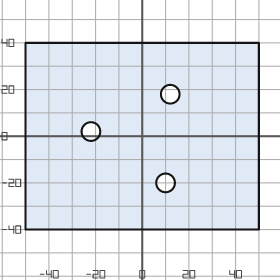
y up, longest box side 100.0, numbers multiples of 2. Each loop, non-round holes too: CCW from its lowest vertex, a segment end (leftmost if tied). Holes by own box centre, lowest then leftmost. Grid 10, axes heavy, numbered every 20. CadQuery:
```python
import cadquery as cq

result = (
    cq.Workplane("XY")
    .moveTo(-50.0, -40.0)
    .lineTo(50.0, -40.0)
    .lineTo(50.0, 40.0)
    .lineTo(-50.0, 40.0)
    .close()
    .moveTo(10.0, -20.0)
    .circle(4.0)
    .moveTo(-22.0, 2.0)
    .circle(4.0)
    .moveTo(12.0, 18.0)
    .circle(4.0)
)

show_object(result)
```